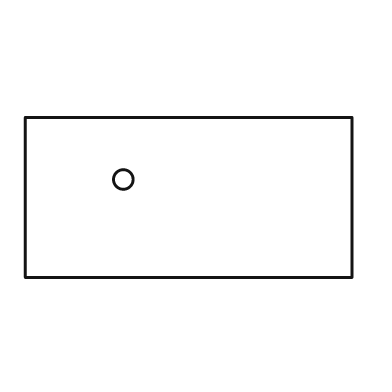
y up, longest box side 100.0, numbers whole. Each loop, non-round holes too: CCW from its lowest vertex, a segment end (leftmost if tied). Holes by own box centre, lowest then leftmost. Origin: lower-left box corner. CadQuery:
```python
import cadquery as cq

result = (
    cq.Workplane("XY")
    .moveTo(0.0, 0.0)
    .lineTo(100.0, 0.0)
    .lineTo(100.0, 49.0)
    .lineTo(0.0, 49.0)
    .close()
    .moveTo(30.0, 30.0)
    .circle(3.0)
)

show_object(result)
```